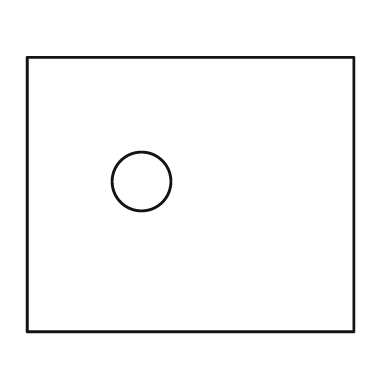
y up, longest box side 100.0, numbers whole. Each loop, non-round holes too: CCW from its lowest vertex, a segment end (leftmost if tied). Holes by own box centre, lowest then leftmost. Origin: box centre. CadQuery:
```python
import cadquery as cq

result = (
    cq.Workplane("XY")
    .moveTo(-50.0, -42.0)
    .lineTo(50.0, -42.0)
    .lineTo(50.0, 42.0)
    .lineTo(-50.0, 42.0)
    .close()
    .moveTo(-15.0, 4.0)
    .circle(9.0)
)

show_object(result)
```